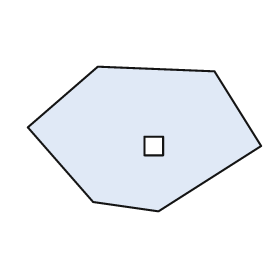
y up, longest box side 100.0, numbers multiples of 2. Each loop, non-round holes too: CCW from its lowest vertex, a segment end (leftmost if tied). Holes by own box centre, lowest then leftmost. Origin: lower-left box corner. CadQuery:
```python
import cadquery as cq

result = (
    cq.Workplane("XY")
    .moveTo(56.0, 0.0)
    .lineTo(100.0, 28.0)
    .lineTo(80.0, 60.0)
    .lineTo(30.0, 62.0)
    .lineTo(0.0, 36.0)
    .lineTo(28.0, 4.0)
    .close()
    .moveTo(50.0, 24.0)
    .lineTo(58.0, 24.0)
    .lineTo(58.0, 32.0)
    .lineTo(50.0, 32.0)
    .close()
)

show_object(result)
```